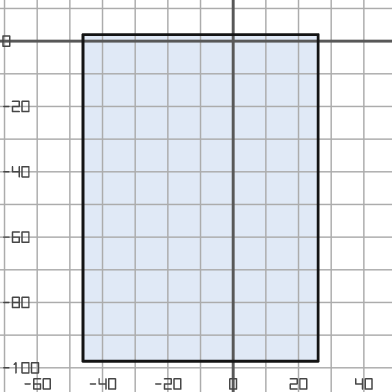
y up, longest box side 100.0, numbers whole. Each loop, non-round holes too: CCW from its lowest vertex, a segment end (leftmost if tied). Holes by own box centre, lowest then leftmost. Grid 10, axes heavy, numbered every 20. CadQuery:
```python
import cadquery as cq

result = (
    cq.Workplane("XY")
    .moveTo(-46.0, -98.0)
    .lineTo(26.0, -98.0)
    .lineTo(26.0, 2.0)
    .lineTo(-46.0, 2.0)
    .close()
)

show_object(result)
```